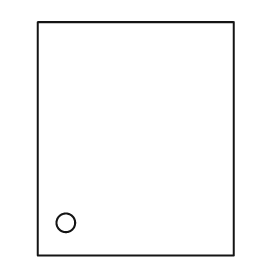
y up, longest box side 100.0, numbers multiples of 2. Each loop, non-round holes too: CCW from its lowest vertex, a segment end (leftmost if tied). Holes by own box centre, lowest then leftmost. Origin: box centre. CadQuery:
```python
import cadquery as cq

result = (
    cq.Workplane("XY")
    .moveTo(-42.0, -50.0)
    .lineTo(42.0, -50.0)
    .lineTo(42.0, 50.0)
    .lineTo(-42.0, 50.0)
    .close()
    .moveTo(-30.0, -36.0)
    .circle(4.0)
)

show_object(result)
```